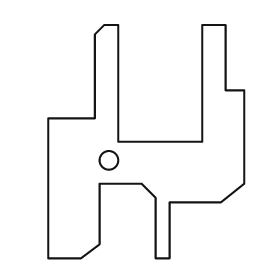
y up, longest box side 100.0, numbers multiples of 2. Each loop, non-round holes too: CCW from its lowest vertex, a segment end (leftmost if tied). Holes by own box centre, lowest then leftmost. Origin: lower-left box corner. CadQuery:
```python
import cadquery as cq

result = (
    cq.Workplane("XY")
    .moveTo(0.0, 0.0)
    .lineTo(14.0, 0.0)
    .lineTo(22.0, 6.0)
    .lineTo(22.0, 32.0)
    .lineTo(40.0, 32.0)
    .lineTo(46.0, 26.0)
    .lineTo(46.0, 0.0)
    .lineTo(52.0, 0.0)
    .lineTo(52.0, 24.0)
    .lineTo(74.0, 24.0)
    .lineTo(84.0, 32.0)
    .lineTo(84.0, 72.0)
    .lineTo(76.0, 72.0)
    .lineTo(76.0, 100.0)
    .lineTo(66.0, 100.0)
    .lineTo(66.0, 50.0)
    .lineTo(30.0, 50.0)
    .lineTo(30.0, 100.0)
    .lineTo(24.0, 100.0)
    .lineTo(20.0, 96.0)
    .lineTo(20.0, 60.0)
    .lineTo(0.0, 60.0)
    .close()
    .moveTo(26.0, 42.0)
    .circle(4.0)
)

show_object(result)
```